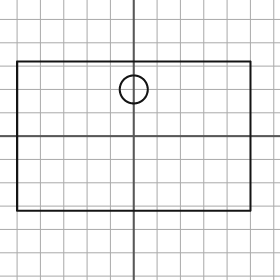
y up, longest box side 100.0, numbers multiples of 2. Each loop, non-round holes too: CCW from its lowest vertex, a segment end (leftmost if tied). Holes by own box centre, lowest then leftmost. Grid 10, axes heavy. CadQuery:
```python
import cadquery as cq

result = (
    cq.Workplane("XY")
    .moveTo(-50.0, -32.0)
    .lineTo(50.0, -32.0)
    .lineTo(50.0, 32.0)
    .lineTo(-50.0, 32.0)
    .close()
    .moveTo(0.0, 20.0)
    .circle(6.0)
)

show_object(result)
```